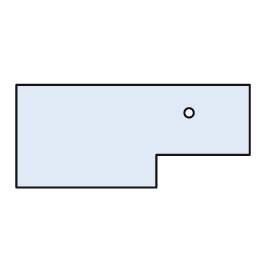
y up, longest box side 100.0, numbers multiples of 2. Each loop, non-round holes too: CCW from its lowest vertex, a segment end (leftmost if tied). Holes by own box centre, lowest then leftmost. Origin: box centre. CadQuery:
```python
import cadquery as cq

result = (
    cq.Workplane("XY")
    .moveTo(-50.0, -22.0)
    .lineTo(10.0, -22.0)
    .lineTo(10.0, -8.0)
    .lineTo(50.0, -8.0)
    .lineTo(50.0, 22.0)
    .lineTo(-50.0, 22.0)
    .close()
    .moveTo(24.0, 10.0)
    .circle(2.0)
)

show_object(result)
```